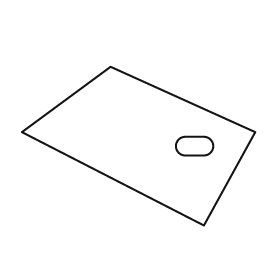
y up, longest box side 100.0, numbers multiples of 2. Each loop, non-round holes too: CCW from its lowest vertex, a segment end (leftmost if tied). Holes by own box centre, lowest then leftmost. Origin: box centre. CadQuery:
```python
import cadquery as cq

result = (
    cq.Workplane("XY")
    .moveTo(28.0, -34.0)
    .lineTo(50.0, 6.0)
    .lineTo(-12.0, 34.0)
    .lineTo(-50.0, 6.0)
    .close()
    .moveTo(20.0, -4.0)
    .lineTo(28.0, -4.0)
    .threePointArc((32.0, 0.0), (28.0, 4.0))
    .lineTo(20.0, 4.0)
    .threePointArc((16.0, 0.0), (20.0, -4.0))
    .close()
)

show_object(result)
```